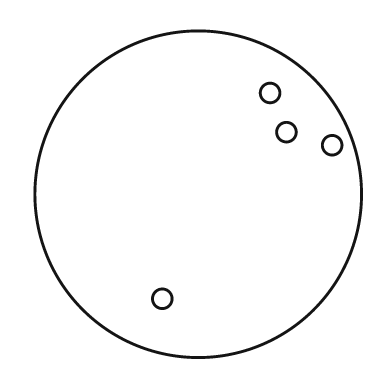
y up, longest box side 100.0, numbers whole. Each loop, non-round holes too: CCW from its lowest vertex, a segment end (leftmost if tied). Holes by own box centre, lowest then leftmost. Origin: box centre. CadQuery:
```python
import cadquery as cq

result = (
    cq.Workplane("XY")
    .moveTo(0.0, 0.0)
    .circle(50.0)
    .moveTo(-11.0, -32.0)
    .circle(3.0)
    .moveTo(41.0, 15.0)
    .circle(3.0)
    .moveTo(27.0, 19.0)
    .circle(3.0)
    .moveTo(22.0, 31.0)
    .circle(3.0)
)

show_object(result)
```